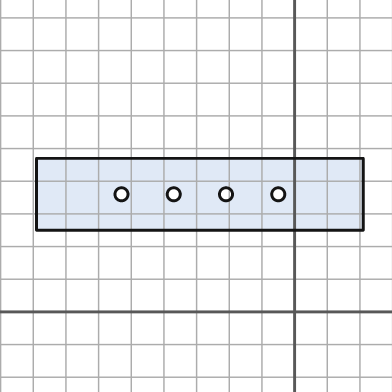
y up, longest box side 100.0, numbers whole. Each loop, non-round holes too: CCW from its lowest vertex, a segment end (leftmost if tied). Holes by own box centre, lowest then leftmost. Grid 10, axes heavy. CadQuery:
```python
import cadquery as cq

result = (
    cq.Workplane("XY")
    .moveTo(-79.0, 25.0)
    .lineTo(21.0, 25.0)
    .lineTo(21.0, 47.0)
    .lineTo(-79.0, 47.0)
    .close()
    .moveTo(-53.0, 36.0)
    .circle(2.0)
    .moveTo(-37.0, 36.0)
    .circle(2.0)
    .moveTo(-21.0, 36.0)
    .circle(2.0)
    .moveTo(-5.0, 36.0)
    .circle(2.0)
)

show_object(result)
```